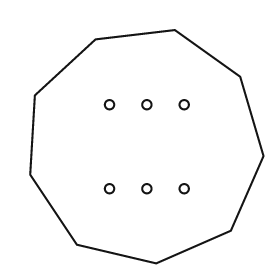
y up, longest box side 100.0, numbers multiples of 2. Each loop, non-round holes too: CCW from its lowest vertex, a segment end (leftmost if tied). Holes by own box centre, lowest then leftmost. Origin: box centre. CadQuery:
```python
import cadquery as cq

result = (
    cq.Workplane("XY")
    .moveTo(4.0, -50.0)
    .lineTo(36.0, -36.0)
    .lineTo(50.0, -4.0)
    .lineTo(40.0, 30.0)
    .lineTo(12.0, 50.0)
    .lineTo(-22.0, 46.0)
    .lineTo(-48.0, 22.0)
    .lineTo(-50.0, -12.0)
    .lineTo(-30.0, -42.0)
    .close()
    .moveTo(-16.0, -18.0)
    .circle(2.0)
    .moveTo(0.0, -18.0)
    .circle(2.0)
    .moveTo(16.0, -18.0)
    .circle(2.0)
    .moveTo(-16.0, 18.0)
    .circle(2.0)
    .moveTo(0.0, 18.0)
    .circle(2.0)
    .moveTo(16.0, 18.0)
    .circle(2.0)
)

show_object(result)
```